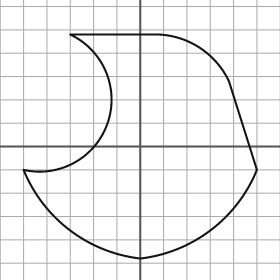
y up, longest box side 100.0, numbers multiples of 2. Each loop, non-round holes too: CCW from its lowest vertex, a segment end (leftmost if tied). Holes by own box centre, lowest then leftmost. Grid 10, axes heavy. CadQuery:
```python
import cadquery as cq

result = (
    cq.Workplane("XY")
    .moveTo(0.0, -48.0)
    .threePointArc((30.0, -36.0), (50.0, -10.0))
    .lineTo(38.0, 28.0)
    .threePointArc((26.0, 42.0), (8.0, 48.0))
    .lineTo(-30.0, 48.0)
    .threePointArc((-14.0, 10.0), (-50.0, -10.0))
    .threePointArc((-30.0, -36.0), (0.0, -48.0))
    .close()
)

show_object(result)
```